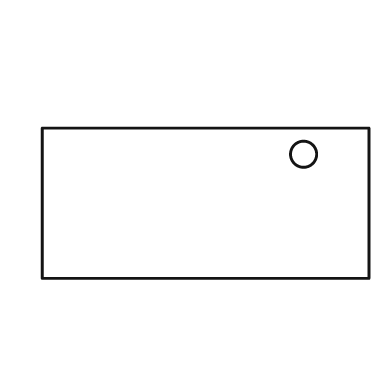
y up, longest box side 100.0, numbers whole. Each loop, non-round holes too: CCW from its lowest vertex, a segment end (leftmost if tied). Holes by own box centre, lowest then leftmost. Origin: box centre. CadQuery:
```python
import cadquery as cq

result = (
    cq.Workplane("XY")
    .moveTo(-50.0, -23.0)
    .lineTo(50.0, -23.0)
    .lineTo(50.0, 23.0)
    .lineTo(-50.0, 23.0)
    .close()
    .moveTo(30.0, 15.0)
    .circle(4.0)
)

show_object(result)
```